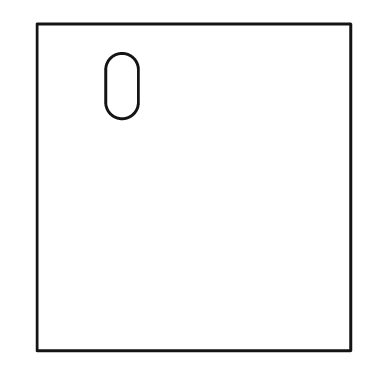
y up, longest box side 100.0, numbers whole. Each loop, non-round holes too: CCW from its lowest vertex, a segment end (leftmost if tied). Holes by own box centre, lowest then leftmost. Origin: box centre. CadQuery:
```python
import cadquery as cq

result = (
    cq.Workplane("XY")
    .moveTo(-48.0, -50.0)
    .lineTo(48.0, -50.0)
    .lineTo(48.0, 50.0)
    .lineTo(-48.0, 50.0)
    .close()
    .moveTo(-27.0, 26.0)
    .threePointArc((-22.0, 21.0), (-17.0, 26.0))
    .lineTo(-17.0, 36.0)
    .threePointArc((-22.0, 41.0), (-27.0, 36.0))
    .close()
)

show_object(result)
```